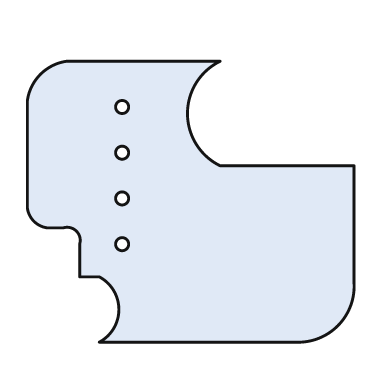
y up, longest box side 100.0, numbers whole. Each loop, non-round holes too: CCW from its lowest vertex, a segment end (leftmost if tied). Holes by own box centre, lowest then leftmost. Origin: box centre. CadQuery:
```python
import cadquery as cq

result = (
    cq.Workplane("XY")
    .moveTo(-28.0, -43.0)
    .lineTo(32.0, -43.0)
    .threePointArc((45.0, -38.0), (50.0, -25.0))
    .lineTo(50.0, 11.0)
    .lineTo(9.0, 11.0)
    .threePointArc((-1.0, 27.0), (9.0, 43.0))
    .lineTo(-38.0, 43.0)
    .threePointArc((-46.0, 39.0), (-50.0, 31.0))
    .lineTo(-50.0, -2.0)
    .threePointArc((-48.0, -6.0), (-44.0, -8.0))
    .lineTo(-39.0, -8.0)
    .threePointArc((-35.0, -9.0), (-34.0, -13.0))
    .lineTo(-34.0, -23.0)
    .lineTo(-28.0, -23.0)
    .threePointArc((-22.0, -33.0), (-28.0, -43.0))
    .close()
    .moveTo(-21.0, -13.0)
    .circle(2.0)
    .moveTo(-21.0, 1.0)
    .circle(2.0)
    .moveTo(-21.0, 15.0)
    .circle(2.0)
    .moveTo(-21.0, 29.0)
    .circle(2.0)
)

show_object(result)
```